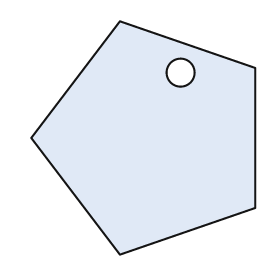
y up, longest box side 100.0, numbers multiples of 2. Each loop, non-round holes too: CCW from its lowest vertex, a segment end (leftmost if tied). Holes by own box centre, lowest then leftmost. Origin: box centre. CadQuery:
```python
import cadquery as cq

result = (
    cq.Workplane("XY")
    .moveTo(-10.0, -50.0)
    .lineTo(48.0, -30.0)
    .lineTo(48.0, 30.0)
    .lineTo(-10.0, 50.0)
    .lineTo(-48.0, 0.0)
    .close()
    .moveTo(16.0, 28.0)
    .circle(6.0)
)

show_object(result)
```